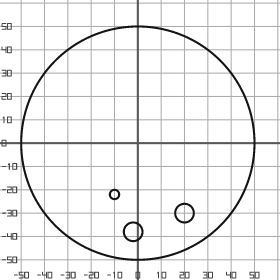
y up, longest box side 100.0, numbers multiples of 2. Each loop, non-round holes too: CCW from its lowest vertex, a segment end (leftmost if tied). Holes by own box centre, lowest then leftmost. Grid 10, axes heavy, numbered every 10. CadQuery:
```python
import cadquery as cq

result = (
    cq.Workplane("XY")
    .moveTo(0.0, 0.0)
    .circle(50.0)
    .moveTo(-2.0, -38.0)
    .circle(4.0)
    .moveTo(20.0, -30.0)
    .circle(4.0)
    .moveTo(-10.0, -22.0)
    .circle(2.0)
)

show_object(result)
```